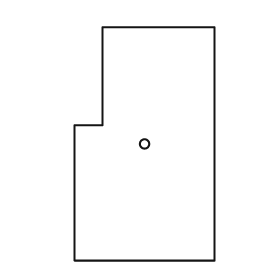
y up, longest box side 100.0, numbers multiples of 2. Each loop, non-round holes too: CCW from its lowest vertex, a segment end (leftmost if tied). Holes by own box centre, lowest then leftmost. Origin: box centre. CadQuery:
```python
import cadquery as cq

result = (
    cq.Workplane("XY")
    .moveTo(-30.0, -50.0)
    .lineTo(30.0, -50.0)
    .lineTo(30.0, 50.0)
    .lineTo(-18.0, 50.0)
    .lineTo(-18.0, 8.0)
    .lineTo(-30.0, 8.0)
    .close()
    .moveTo(0.0, 0.0)
    .circle(2.0)
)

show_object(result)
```